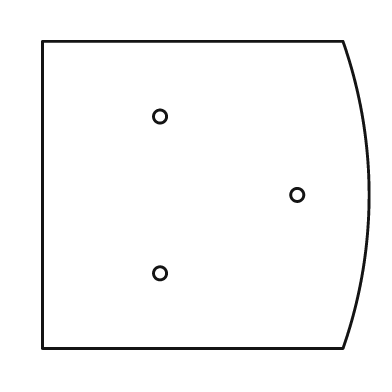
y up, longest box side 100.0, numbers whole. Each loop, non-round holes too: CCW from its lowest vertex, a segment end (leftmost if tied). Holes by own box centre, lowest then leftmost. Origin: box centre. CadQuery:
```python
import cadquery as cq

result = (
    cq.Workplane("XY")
    .moveTo(-50.0, -47.0)
    .lineTo(42.0, -47.0)
    .threePointArc((50.0, 0.0), (42.0, 47.0))
    .lineTo(-50.0, 47.0)
    .close()
    .moveTo(-14.0, -24.0)
    .circle(2.0)
    .moveTo(28.0, 0.0)
    .circle(2.0)
    .moveTo(-14.0, 24.0)
    .circle(2.0)
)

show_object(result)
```